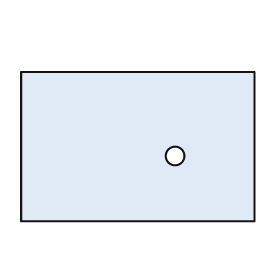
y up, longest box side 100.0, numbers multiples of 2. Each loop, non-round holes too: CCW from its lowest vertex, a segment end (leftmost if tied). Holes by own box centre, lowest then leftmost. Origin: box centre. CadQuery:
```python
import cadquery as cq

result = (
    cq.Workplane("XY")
    .moveTo(-50.0, -32.0)
    .lineTo(50.0, -32.0)
    .lineTo(50.0, 32.0)
    .lineTo(-50.0, 32.0)
    .close()
    .moveTo(16.0, -4.0)
    .circle(4.0)
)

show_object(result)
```